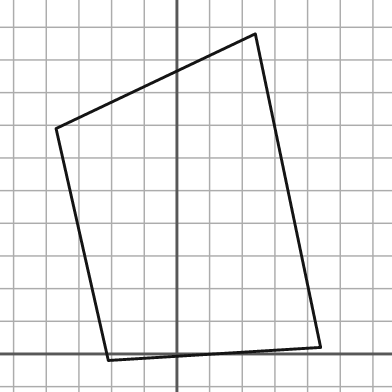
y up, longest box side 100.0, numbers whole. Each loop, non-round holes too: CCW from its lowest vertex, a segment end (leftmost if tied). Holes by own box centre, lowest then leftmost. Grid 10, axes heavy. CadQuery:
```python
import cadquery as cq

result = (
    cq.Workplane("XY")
    .moveTo(-21.0, -2.0)
    .lineTo(44.0, 2.0)
    .lineTo(24.0, 98.0)
    .lineTo(-37.0, 69.0)
    .close()
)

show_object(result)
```